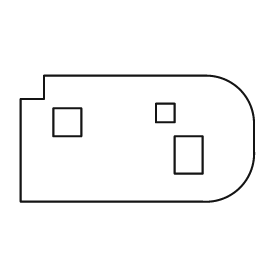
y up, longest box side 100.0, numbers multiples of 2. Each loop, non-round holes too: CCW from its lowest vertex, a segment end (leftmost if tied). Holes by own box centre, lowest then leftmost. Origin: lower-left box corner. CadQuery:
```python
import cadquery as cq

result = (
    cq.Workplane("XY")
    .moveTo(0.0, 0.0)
    .lineTo(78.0, 0.0)
    .threePointArc((94.0, 6.0), (100.0, 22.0))
    .lineTo(100.0, 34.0)
    .threePointArc((94.0, 48.0), (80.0, 54.0))
    .lineTo(10.0, 54.0)
    .lineTo(10.0, 44.0)
    .lineTo(0.0, 44.0)
    .close()
    .moveTo(66.0, 12.0)
    .lineTo(78.0, 12.0)
    .lineTo(78.0, 28.0)
    .lineTo(66.0, 28.0)
    .close()
    .moveTo(14.0, 28.0)
    .lineTo(26.0, 28.0)
    .lineTo(26.0, 40.0)
    .lineTo(14.0, 40.0)
    .close()
    .moveTo(58.0, 34.0)
    .lineTo(66.0, 34.0)
    .lineTo(66.0, 42.0)
    .lineTo(58.0, 42.0)
    .close()
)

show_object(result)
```